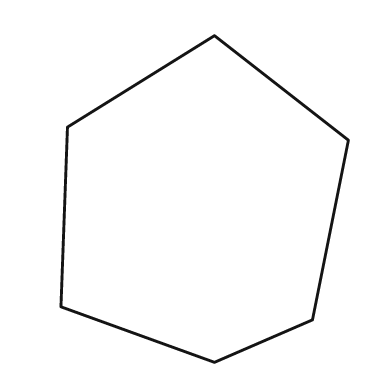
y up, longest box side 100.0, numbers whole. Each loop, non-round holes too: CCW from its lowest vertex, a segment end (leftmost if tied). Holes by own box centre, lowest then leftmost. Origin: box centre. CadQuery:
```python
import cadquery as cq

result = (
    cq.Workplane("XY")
    .moveTo(3.0, -50.0)
    .lineTo(33.0, -37.0)
    .lineTo(44.0, 18.0)
    .lineTo(3.0, 50.0)
    .lineTo(-42.0, 22.0)
    .lineTo(-44.0, -33.0)
    .close()
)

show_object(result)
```